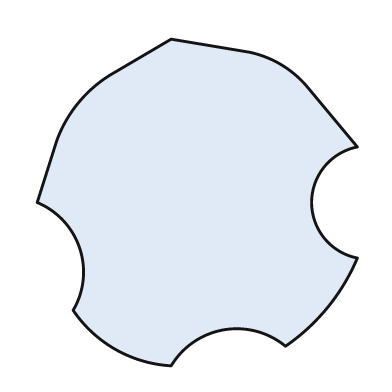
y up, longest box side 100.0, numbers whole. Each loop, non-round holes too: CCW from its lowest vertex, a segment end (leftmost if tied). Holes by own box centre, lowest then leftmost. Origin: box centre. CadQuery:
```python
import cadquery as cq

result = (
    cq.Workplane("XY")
    .moveTo(-8.0, -50.0)
    .threePointArc((8.0, -39.0), (27.0, -44.0))
    .threePointArc((40.0, -32.0), (49.0, -17.0))
    .threePointArc((35.0, 0.0), (49.0, 17.0))
    .lineTo(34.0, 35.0)
    .threePointArc((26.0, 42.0), (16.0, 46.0))
    .lineTo(-8.0, 50.0)
    .lineTo(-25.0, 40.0)
    .threePointArc((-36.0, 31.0), (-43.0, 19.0))
    .lineTo(-49.0, 0.0)
    .threePointArc((-36.0, -14.0), (-38.0, -33.0))
    .threePointArc((-25.0, -45.0), (-8.0, -50.0))
    .close()
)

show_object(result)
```